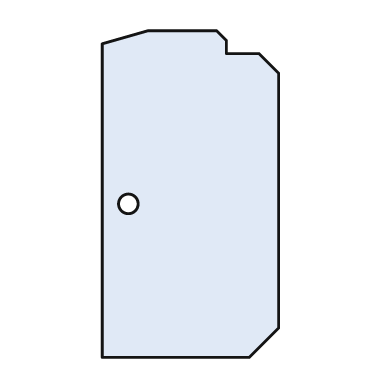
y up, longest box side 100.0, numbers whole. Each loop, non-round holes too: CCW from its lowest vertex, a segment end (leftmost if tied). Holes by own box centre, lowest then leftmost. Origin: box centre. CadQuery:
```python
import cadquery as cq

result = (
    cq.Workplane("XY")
    .moveTo(-27.0, -50.0)
    .lineTo(18.0, -50.0)
    .lineTo(27.0, -41.0)
    .lineTo(27.0, 37.0)
    .lineTo(21.0, 43.0)
    .lineTo(11.0, 43.0)
    .lineTo(11.0, 47.0)
    .lineTo(8.0, 50.0)
    .lineTo(-13.0, 50.0)
    .lineTo(-27.0, 46.0)
    .close()
    .moveTo(-19.0, -3.0)
    .circle(3.0)
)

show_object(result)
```